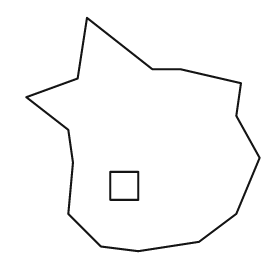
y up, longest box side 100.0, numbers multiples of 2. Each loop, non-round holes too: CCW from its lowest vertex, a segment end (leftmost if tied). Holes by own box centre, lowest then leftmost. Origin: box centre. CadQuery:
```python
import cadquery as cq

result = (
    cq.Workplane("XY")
    .moveTo(-2.0, -50.0)
    .lineTo(24.0, -46.0)
    .lineTo(40.0, -34.0)
    .lineTo(50.0, -10.0)
    .lineTo(40.0, 8.0)
    .lineTo(42.0, 22.0)
    .lineTo(16.0, 28.0)
    .lineTo(4.0, 28.0)
    .lineTo(-24.0, 50.0)
    .lineTo(-28.0, 24.0)
    .lineTo(-50.0, 16.0)
    .lineTo(-32.0, 2.0)
    .lineTo(-30.0, -12.0)
    .lineTo(-32.0, -34.0)
    .lineTo(-18.0, -48.0)
    .close()
    .moveTo(-14.0, -28.0)
    .lineTo(-2.0, -28.0)
    .lineTo(-2.0, -16.0)
    .lineTo(-14.0, -16.0)
    .close()
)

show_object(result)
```